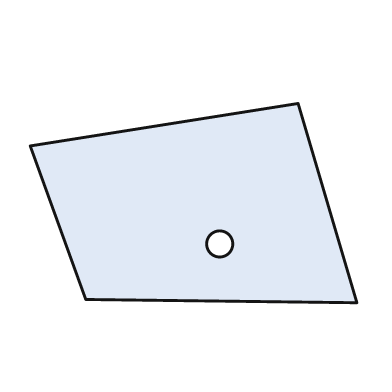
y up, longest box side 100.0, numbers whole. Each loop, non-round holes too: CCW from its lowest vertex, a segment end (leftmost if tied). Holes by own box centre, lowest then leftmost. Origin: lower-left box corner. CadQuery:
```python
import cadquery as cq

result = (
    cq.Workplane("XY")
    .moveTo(100.0, 0.0)
    .lineTo(82.0, 61.0)
    .lineTo(0.0, 48.0)
    .lineTo(17.0, 1.0)
    .close()
    .moveTo(58.0, 18.0)
    .circle(4.0)
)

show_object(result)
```